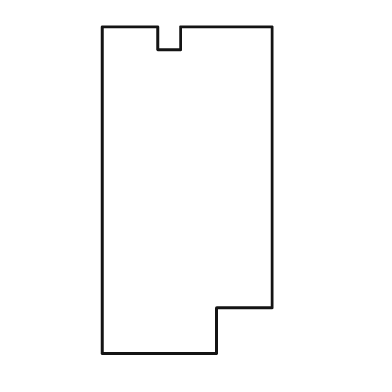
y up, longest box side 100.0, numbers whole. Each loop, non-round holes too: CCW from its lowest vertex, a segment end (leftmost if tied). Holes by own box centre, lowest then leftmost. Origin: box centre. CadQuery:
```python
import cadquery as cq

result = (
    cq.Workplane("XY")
    .moveTo(-26.0, -50.0)
    .lineTo(9.0, -50.0)
    .lineTo(9.0, -36.0)
    .lineTo(26.0, -36.0)
    .lineTo(26.0, 50.0)
    .lineTo(-2.0, 50.0)
    .lineTo(-2.0, 43.0)
    .lineTo(-9.0, 43.0)
    .lineTo(-9.0, 50.0)
    .lineTo(-26.0, 50.0)
    .close()
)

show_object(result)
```